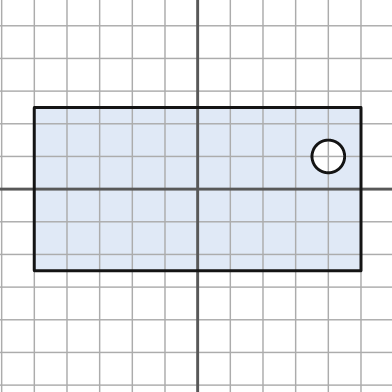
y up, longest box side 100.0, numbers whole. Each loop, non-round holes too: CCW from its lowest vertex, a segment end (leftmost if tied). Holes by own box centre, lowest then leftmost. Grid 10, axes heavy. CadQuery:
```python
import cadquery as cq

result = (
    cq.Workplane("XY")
    .moveTo(-50.0, -25.0)
    .lineTo(50.0, -25.0)
    .lineTo(50.0, 25.0)
    .lineTo(-50.0, 25.0)
    .close()
    .moveTo(40.0, 10.0)
    .circle(5.0)
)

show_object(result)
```